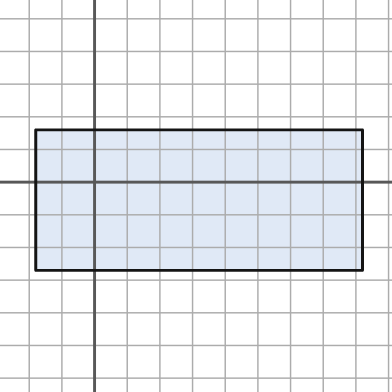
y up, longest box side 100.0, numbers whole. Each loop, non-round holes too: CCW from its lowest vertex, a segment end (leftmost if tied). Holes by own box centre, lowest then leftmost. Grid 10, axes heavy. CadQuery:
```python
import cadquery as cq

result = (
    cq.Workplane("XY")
    .moveTo(-18.0, -27.0)
    .lineTo(82.0, -27.0)
    .lineTo(82.0, 16.0)
    .lineTo(-18.0, 16.0)
    .close()
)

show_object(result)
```